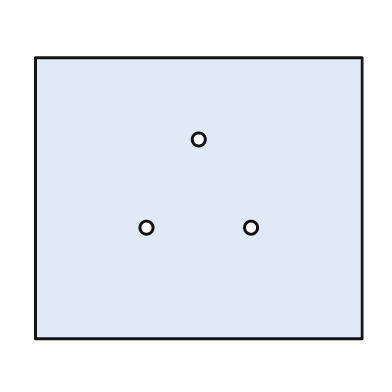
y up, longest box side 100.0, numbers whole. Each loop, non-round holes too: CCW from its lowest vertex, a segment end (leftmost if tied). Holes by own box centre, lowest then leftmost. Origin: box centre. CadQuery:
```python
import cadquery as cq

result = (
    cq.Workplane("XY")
    .moveTo(-50.0, -43.0)
    .lineTo(50.0, -43.0)
    .lineTo(50.0, 43.0)
    .lineTo(-50.0, 43.0)
    .close()
    .moveTo(-16.0, -9.0)
    .circle(2.0)
    .moveTo(16.0, -9.0)
    .circle(2.0)
    .moveTo(0.0, 18.0)
    .circle(2.0)
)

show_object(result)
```